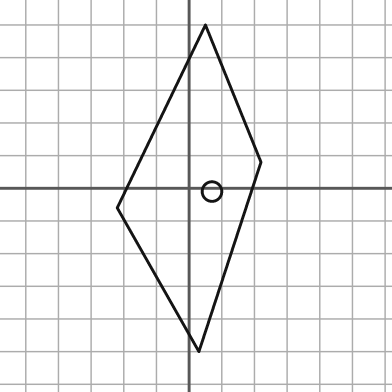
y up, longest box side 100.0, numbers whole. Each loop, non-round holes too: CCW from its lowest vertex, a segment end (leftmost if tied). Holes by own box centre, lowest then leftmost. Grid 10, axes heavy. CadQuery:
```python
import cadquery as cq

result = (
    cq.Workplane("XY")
    .moveTo(3.0, -50.0)
    .lineTo(22.0, 8.0)
    .lineTo(5.0, 50.0)
    .lineTo(-22.0, -6.0)
    .close()
    .moveTo(7.0, -1.0)
    .circle(3.0)
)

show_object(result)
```